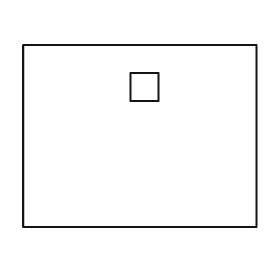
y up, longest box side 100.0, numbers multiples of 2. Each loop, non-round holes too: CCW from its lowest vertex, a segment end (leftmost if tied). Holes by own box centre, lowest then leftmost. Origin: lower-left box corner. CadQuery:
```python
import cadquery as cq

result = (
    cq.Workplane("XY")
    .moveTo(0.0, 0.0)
    .lineTo(100.0, 0.0)
    .lineTo(100.0, 78.0)
    .lineTo(0.0, 78.0)
    .close()
    .moveTo(46.0, 54.0)
    .lineTo(58.0, 54.0)
    .lineTo(58.0, 66.0)
    .lineTo(46.0, 66.0)
    .close()
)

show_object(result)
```